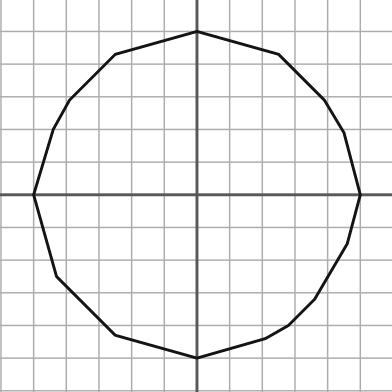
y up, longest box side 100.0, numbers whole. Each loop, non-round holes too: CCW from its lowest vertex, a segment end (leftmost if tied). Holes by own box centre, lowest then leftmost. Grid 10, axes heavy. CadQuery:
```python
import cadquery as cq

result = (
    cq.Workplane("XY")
    .moveTo(0.0, -50.0)
    .lineTo(21.0, -44.0)
    .lineTo(28.0, -40.0)
    .lineTo(36.0, -32.0)
    .lineTo(46.0, -15.0)
    .lineTo(50.0, 0.0)
    .lineTo(45.0, 19.0)
    .lineTo(39.0, 29.0)
    .lineTo(25.0, 43.0)
    .lineTo(0.0, 50.0)
    .lineTo(-25.0, 43.0)
    .lineTo(-39.0, 29.0)
    .lineTo(-44.0, 20.0)
    .lineTo(-50.0, 0.0)
    .lineTo(-43.0, -25.0)
    .lineTo(-25.0, -43.0)
    .close()
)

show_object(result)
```